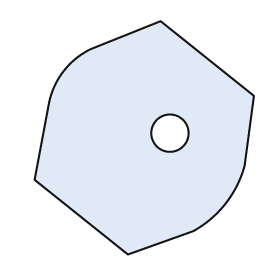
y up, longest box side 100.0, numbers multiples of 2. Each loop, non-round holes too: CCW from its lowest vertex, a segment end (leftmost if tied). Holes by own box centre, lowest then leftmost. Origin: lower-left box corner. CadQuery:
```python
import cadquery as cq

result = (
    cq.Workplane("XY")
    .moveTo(40.0, 0.0)
    .lineTo(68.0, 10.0)
    .threePointArc((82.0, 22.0), (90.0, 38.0))
    .lineTo(94.0, 68.0)
    .lineTo(54.0, 100.0)
    .lineTo(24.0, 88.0)
    .threePointArc((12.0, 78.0), (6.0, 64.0))
    .lineTo(0.0, 32.0)
    .close()
    .moveTo(58.0, 52.0)
    .circle(8.0)
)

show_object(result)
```